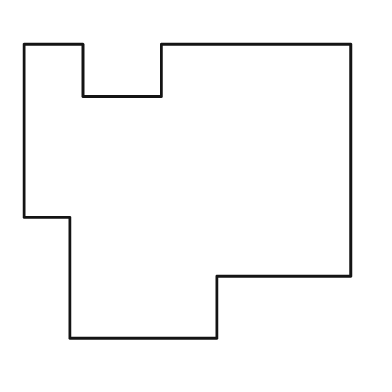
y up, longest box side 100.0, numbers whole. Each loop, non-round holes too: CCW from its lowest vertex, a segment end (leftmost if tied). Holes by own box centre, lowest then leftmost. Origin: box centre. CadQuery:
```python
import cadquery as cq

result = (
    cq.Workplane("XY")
    .moveTo(-36.0, -45.0)
    .lineTo(9.0, -45.0)
    .lineTo(9.0, -26.0)
    .lineTo(50.0, -26.0)
    .lineTo(50.0, 45.0)
    .lineTo(-8.0, 45.0)
    .lineTo(-8.0, 29.0)
    .lineTo(-32.0, 29.0)
    .lineTo(-32.0, 45.0)
    .lineTo(-50.0, 45.0)
    .lineTo(-50.0, -8.0)
    .lineTo(-36.0, -8.0)
    .close()
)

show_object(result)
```